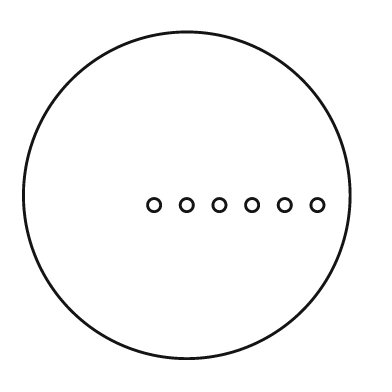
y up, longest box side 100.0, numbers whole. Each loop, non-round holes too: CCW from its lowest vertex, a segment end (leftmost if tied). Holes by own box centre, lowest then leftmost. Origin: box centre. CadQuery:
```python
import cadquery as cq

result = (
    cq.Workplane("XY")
    .moveTo(0.0, 0.0)
    .circle(50.0)
    .moveTo(-10.0, -3.0)
    .circle(2.0)
    .moveTo(0.0, -3.0)
    .circle(2.0)
    .moveTo(10.0, -3.0)
    .circle(2.0)
    .moveTo(20.0, -3.0)
    .circle(2.0)
    .moveTo(30.0, -3.0)
    .circle(2.0)
    .moveTo(40.0, -3.0)
    .circle(2.0)
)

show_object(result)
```